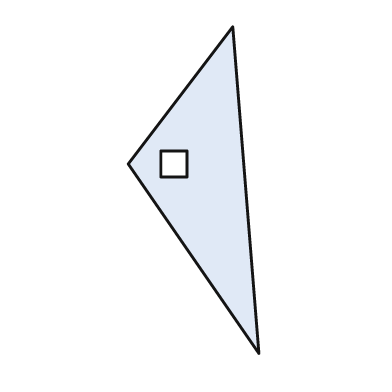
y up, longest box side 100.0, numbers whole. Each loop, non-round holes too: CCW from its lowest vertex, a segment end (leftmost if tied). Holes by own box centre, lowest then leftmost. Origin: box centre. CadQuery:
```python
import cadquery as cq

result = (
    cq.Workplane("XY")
    .moveTo(20.0, -50.0)
    .lineTo(12.0, 50.0)
    .lineTo(-20.0, 8.0)
    .close()
    .moveTo(-10.0, 4.0)
    .lineTo(-2.0, 4.0)
    .lineTo(-2.0, 12.0)
    .lineTo(-10.0, 12.0)
    .close()
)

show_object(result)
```